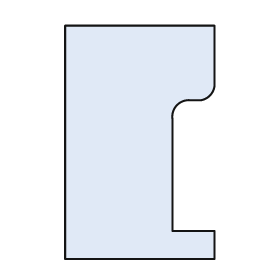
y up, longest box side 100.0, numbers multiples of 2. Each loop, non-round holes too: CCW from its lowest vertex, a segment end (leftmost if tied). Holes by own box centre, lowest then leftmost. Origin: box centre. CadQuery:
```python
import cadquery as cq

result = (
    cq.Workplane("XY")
    .moveTo(-32.0, -50.0)
    .lineTo(32.0, -50.0)
    .lineTo(32.0, -38.0)
    .lineTo(14.0, -38.0)
    .lineTo(14.0, 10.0)
    .threePointArc((16.0, 16.0), (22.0, 18.0))
    .lineTo(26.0, 18.0)
    .threePointArc((30.0, 20.0), (32.0, 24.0))
    .lineTo(32.0, 50.0)
    .lineTo(-32.0, 50.0)
    .close()
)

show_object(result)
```